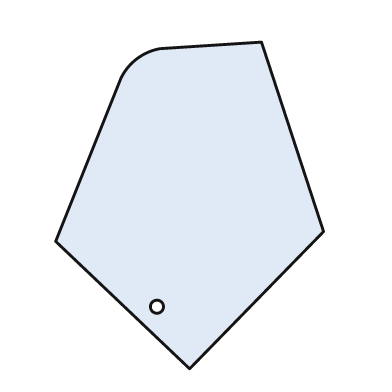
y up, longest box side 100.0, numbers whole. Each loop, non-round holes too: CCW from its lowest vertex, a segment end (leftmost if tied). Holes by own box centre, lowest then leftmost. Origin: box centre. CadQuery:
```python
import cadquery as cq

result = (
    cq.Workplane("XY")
    .moveTo(0.0, -50.0)
    .lineTo(41.0, -8.0)
    .lineTo(22.0, 50.0)
    .lineTo(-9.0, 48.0)
    .threePointArc((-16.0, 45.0), (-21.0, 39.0))
    .lineTo(-41.0, -11.0)
    .close()
    .moveTo(-10.0, -31.0)
    .circle(2.0)
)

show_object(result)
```